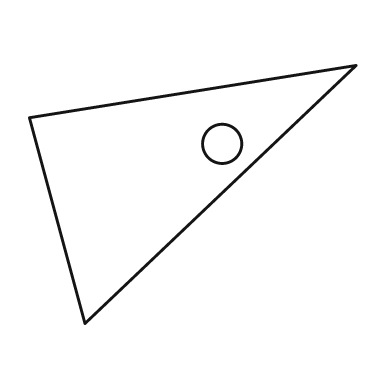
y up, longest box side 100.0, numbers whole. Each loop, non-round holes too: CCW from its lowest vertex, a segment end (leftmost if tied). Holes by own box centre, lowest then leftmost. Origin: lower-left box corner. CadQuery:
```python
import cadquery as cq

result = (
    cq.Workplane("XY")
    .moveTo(17.0, 0.0)
    .lineTo(100.0, 79.0)
    .lineTo(0.0, 63.0)
    .close()
    .moveTo(59.0, 55.0)
    .circle(6.0)
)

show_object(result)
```